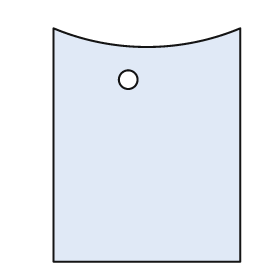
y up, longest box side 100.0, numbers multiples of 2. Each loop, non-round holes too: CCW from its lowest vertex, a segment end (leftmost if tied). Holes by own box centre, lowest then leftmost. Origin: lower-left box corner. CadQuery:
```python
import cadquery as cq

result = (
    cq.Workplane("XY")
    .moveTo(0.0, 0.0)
    .lineTo(80.0, 0.0)
    .lineTo(80.0, 100.0)
    .threePointArc((40.0, 92.0), (0.0, 100.0))
    .close()
    .moveTo(32.0, 78.0)
    .circle(4.0)
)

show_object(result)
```